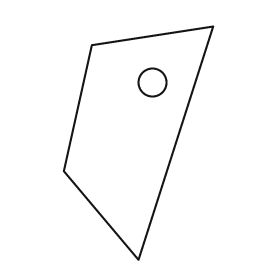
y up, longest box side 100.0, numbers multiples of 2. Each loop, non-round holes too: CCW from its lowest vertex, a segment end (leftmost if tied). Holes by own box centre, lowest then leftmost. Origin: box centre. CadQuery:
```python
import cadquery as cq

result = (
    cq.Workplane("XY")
    .moveTo(0.0, -50.0)
    .lineTo(32.0, 50.0)
    .lineTo(-20.0, 42.0)
    .lineTo(-32.0, -12.0)
    .close()
    .moveTo(6.0, 26.0)
    .circle(6.0)
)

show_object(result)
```